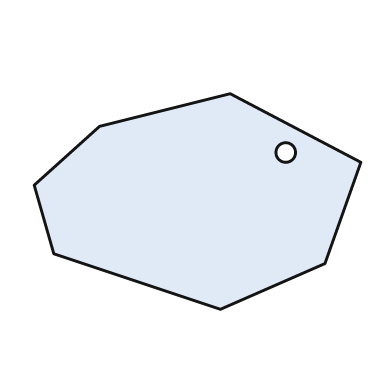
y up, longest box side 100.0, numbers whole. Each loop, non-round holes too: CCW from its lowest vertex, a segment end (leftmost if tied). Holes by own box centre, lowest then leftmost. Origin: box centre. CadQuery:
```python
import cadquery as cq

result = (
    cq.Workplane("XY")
    .moveTo(7.0, -33.0)
    .lineTo(39.0, -19.0)
    .lineTo(50.0, 12.0)
    .lineTo(10.0, 33.0)
    .lineTo(-30.0, 23.0)
    .lineTo(-50.0, 5.0)
    .lineTo(-44.0, -16.0)
    .close()
    .moveTo(27.0, 15.0)
    .circle(3.0)
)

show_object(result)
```